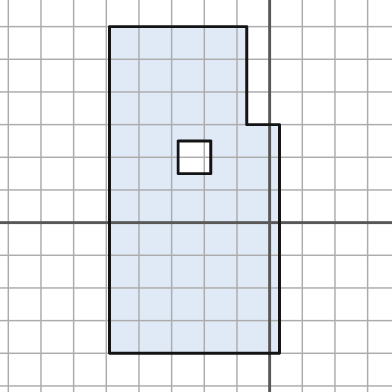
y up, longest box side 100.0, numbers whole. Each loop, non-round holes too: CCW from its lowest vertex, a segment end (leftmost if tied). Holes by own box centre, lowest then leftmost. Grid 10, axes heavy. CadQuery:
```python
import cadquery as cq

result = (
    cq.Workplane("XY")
    .moveTo(-49.0, -40.0)
    .lineTo(3.0, -40.0)
    .lineTo(3.0, 30.0)
    .lineTo(-7.0, 30.0)
    .lineTo(-7.0, 60.0)
    .lineTo(-49.0, 60.0)
    .close()
    .moveTo(-28.0, 15.0)
    .lineTo(-18.0, 15.0)
    .lineTo(-18.0, 25.0)
    .lineTo(-28.0, 25.0)
    .close()
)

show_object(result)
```